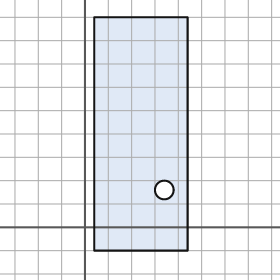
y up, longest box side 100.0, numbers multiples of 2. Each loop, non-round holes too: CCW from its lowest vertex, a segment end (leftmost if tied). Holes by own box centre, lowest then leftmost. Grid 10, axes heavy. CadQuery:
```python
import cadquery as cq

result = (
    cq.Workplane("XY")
    .moveTo(4.0, -10.0)
    .lineTo(44.0, -10.0)
    .lineTo(44.0, 90.0)
    .lineTo(4.0, 90.0)
    .close()
    .moveTo(34.0, 16.0)
    .circle(4.0)
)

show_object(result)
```